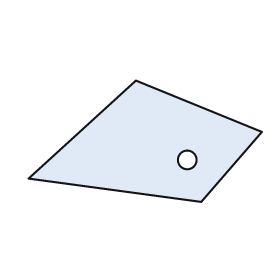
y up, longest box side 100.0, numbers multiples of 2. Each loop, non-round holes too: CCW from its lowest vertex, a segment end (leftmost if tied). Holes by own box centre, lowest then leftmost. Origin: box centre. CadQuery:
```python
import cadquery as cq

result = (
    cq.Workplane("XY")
    .moveTo(24.0, -26.0)
    .lineTo(50.0, 4.0)
    .lineTo(-4.0, 26.0)
    .lineTo(-50.0, -16.0)
    .close()
    .moveTo(18.0, -8.0)
    .circle(4.0)
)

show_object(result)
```